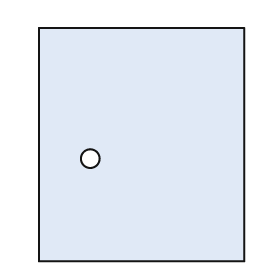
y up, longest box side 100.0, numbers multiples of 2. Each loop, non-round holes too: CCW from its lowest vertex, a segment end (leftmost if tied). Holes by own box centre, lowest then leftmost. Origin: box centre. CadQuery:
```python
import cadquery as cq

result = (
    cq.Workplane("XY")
    .moveTo(-44.0, -50.0)
    .lineTo(44.0, -50.0)
    .lineTo(44.0, 50.0)
    .lineTo(-44.0, 50.0)
    .close()
    .moveTo(-22.0, -6.0)
    .circle(4.0)
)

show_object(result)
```